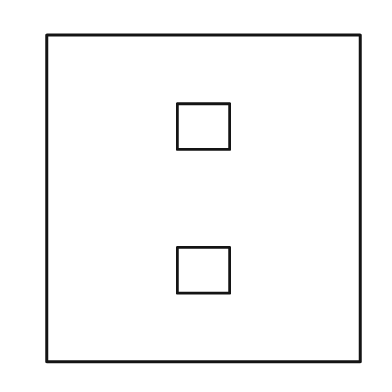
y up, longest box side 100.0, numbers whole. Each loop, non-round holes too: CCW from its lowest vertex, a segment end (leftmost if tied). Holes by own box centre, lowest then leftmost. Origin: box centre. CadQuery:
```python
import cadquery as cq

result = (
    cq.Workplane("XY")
    .moveTo(-48.0, -50.0)
    .lineTo(48.0, -50.0)
    .lineTo(48.0, 50.0)
    .lineTo(-48.0, 50.0)
    .close()
    .moveTo(-8.0, -29.0)
    .lineTo(8.0, -29.0)
    .lineTo(8.0, -15.0)
    .lineTo(-8.0, -15.0)
    .close()
    .moveTo(-8.0, 15.0)
    .lineTo(8.0, 15.0)
    .lineTo(8.0, 29.0)
    .lineTo(-8.0, 29.0)
    .close()
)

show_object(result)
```